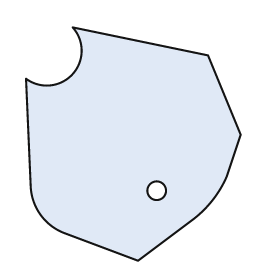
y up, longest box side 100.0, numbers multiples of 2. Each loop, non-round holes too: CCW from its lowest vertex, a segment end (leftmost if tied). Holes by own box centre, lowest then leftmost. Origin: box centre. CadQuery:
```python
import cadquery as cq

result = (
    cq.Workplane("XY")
    .moveTo(2.0, -50.0)
    .lineTo(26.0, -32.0)
    .threePointArc((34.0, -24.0), (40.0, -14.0))
    .lineTo(46.0, 4.0)
    .lineTo(32.0, 38.0)
    .lineTo(-26.0, 50.0)
    .threePointArc((-26.0, 30.0), (-46.0, 28.0))
    .lineTo(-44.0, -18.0)
    .threePointArc((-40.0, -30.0), (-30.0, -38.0))
    .close()
    .moveTo(10.0, -20.0)
    .circle(4.0)
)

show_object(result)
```